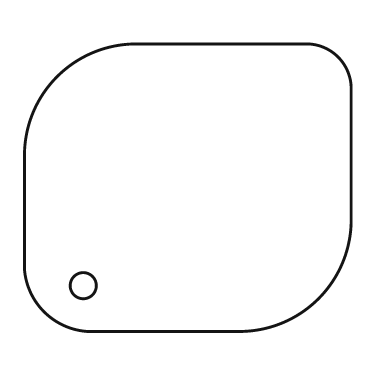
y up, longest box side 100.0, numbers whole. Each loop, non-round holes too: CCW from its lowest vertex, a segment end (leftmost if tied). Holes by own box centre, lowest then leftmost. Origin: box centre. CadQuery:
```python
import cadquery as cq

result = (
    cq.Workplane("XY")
    .moveTo(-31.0, -44.0)
    .lineTo(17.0, -44.0)
    .threePointArc((40.0, -34.0), (50.0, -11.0))
    .lineTo(50.0, 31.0)
    .threePointArc((46.0, 40.0), (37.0, 44.0))
    .lineTo(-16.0, 44.0)
    .threePointArc((-40.0, 34.0), (-50.0, 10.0))
    .lineTo(-50.0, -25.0)
    .threePointArc((-44.0, -38.0), (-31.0, -44.0))
    .close()
    .moveTo(-32.0, -30.0)
    .circle(4.0)
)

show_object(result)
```